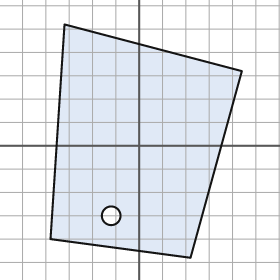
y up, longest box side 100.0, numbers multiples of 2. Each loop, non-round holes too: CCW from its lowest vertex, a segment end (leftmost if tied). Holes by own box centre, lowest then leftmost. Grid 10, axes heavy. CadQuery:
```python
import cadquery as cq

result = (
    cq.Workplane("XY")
    .moveTo(22.0, -48.0)
    .lineTo(44.0, 32.0)
    .lineTo(-32.0, 52.0)
    .lineTo(-38.0, -40.0)
    .close()
    .moveTo(-12.0, -30.0)
    .circle(4.0)
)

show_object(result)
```